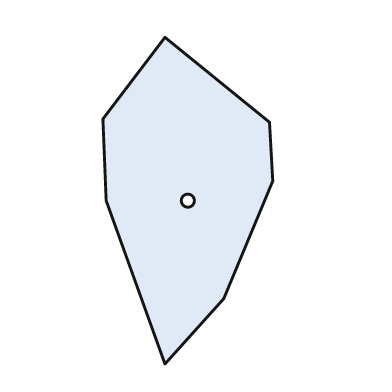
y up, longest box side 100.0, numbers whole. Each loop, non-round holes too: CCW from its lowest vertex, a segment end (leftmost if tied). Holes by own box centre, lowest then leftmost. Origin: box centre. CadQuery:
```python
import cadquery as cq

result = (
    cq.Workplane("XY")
    .moveTo(-7.0, -50.0)
    .lineTo(11.0, -30.0)
    .lineTo(26.0, 6.0)
    .lineTo(25.0, 24.0)
    .lineTo(-7.0, 50.0)
    .lineTo(-26.0, 25.0)
    .lineTo(-25.0, 0.0)
    .close()
    .moveTo(0.0, 0.0)
    .circle(2.0)
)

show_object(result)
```